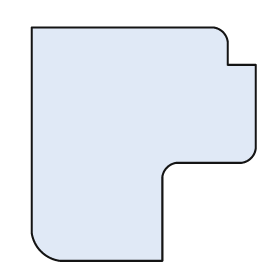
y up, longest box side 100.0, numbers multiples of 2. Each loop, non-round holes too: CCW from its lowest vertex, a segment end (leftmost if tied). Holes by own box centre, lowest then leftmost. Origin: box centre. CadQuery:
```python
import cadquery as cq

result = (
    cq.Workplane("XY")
    .moveTo(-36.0, -50.0)
    .lineTo(8.0, -50.0)
    .lineTo(8.0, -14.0)
    .threePointArc((10.0, -10.0), (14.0, -8.0))
    .lineTo(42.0, -8.0)
    .threePointArc((46.0, -6.0), (48.0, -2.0))
    .lineTo(48.0, 34.0)
    .lineTo(36.0, 34.0)
    .lineTo(36.0, 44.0)
    .threePointArc((34.0, 48.0), (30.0, 50.0))
    .lineTo(-48.0, 50.0)
    .lineTo(-48.0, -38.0)
    .threePointArc((-44.0, -46.0), (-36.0, -50.0))
    .close()
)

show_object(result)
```